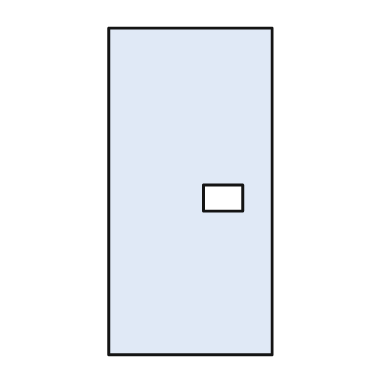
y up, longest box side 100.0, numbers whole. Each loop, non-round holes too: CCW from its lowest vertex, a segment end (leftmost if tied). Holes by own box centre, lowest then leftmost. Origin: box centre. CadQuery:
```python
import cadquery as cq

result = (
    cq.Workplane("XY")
    .moveTo(-25.0, -50.0)
    .lineTo(25.0, -50.0)
    .lineTo(25.0, 50.0)
    .lineTo(-25.0, 50.0)
    .close()
    .moveTo(4.0, -6.0)
    .lineTo(16.0, -6.0)
    .lineTo(16.0, 2.0)
    .lineTo(4.0, 2.0)
    .close()
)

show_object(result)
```